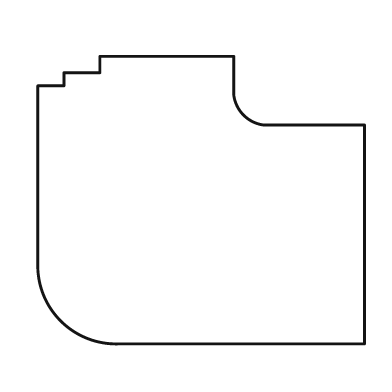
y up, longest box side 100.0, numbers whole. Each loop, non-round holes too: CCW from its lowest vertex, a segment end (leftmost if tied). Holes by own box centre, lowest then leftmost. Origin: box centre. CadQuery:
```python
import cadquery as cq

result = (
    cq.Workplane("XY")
    .moveTo(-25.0, -44.0)
    .lineTo(50.0, -44.0)
    .lineTo(50.0, 23.0)
    .lineTo(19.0, 23.0)
    .threePointArc((13.0, 26.0), (10.0, 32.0))
    .lineTo(10.0, 44.0)
    .lineTo(-31.0, 44.0)
    .lineTo(-31.0, 39.0)
    .lineTo(-42.0, 39.0)
    .lineTo(-42.0, 35.0)
    .lineTo(-50.0, 35.0)
    .lineTo(-50.0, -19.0)
    .threePointArc((-43.0, -37.0), (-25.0, -44.0))
    .close()
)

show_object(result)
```